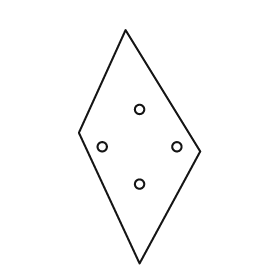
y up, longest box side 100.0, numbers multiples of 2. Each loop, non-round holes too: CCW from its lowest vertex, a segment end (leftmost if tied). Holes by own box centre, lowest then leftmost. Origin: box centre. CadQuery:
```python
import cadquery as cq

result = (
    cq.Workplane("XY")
    .moveTo(0.0, -50.0)
    .lineTo(26.0, -2.0)
    .lineTo(-6.0, 50.0)
    .lineTo(-26.0, 6.0)
    .close()
    .moveTo(0.0, -16.0)
    .circle(2.0)
    .moveTo(-16.0, 0.0)
    .circle(2.0)
    .moveTo(16.0, 0.0)
    .circle(2.0)
    .moveTo(0.0, 16.0)
    .circle(2.0)
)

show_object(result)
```